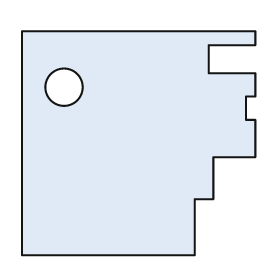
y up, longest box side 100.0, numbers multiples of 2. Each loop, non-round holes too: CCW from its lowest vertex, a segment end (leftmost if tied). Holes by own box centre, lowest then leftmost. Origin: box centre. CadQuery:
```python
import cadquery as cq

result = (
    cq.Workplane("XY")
    .moveTo(-50.0, -48.0)
    .lineTo(24.0, -48.0)
    .lineTo(24.0, -24.0)
    .lineTo(32.0, -24.0)
    .lineTo(32.0, -6.0)
    .lineTo(50.0, -6.0)
    .lineTo(50.0, 10.0)
    .lineTo(46.0, 10.0)
    .lineTo(46.0, 20.0)
    .lineTo(50.0, 20.0)
    .lineTo(50.0, 30.0)
    .lineTo(30.0, 30.0)
    .lineTo(30.0, 42.0)
    .lineTo(50.0, 42.0)
    .lineTo(50.0, 48.0)
    .lineTo(-50.0, 48.0)
    .close()
    .moveTo(-32.0, 24.0)
    .circle(8.0)
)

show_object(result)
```